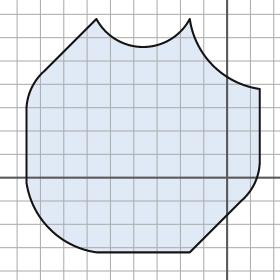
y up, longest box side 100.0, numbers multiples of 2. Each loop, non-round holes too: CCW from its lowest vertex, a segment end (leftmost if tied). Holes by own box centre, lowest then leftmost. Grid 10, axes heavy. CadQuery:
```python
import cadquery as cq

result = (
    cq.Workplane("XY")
    .moveTo(-56.0, -32.0)
    .lineTo(-16.0, -32.0)
    .lineTo(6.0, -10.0)
    .threePointArc((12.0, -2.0), (14.0, 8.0))
    .lineTo(14.0, 38.0)
    .threePointArc((-6.0, 48.0), (-16.0, 68.0))
    .threePointArc((-36.0, 56.0), (-56.0, 68.0))
    .lineTo(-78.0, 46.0)
    .threePointArc((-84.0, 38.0), (-86.0, 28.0))
    .lineTo(-86.0, -2.0)
    .threePointArc((-76.0, -22.0), (-56.0, -32.0))
    .close()
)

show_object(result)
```